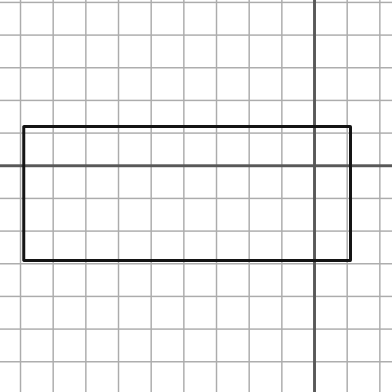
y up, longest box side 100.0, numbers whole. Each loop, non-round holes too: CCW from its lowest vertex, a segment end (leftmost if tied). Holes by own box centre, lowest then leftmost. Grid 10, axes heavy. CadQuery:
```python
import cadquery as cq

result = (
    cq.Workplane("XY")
    .moveTo(-89.0, -29.0)
    .lineTo(11.0, -29.0)
    .lineTo(11.0, 12.0)
    .lineTo(-89.0, 12.0)
    .close()
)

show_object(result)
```